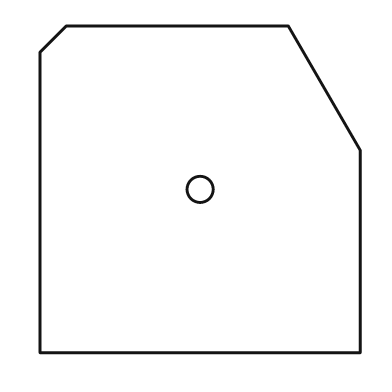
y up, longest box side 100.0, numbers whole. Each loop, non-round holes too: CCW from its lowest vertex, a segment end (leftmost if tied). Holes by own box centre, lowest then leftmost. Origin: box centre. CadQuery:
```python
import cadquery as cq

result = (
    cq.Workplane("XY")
    .moveTo(-49.0, -50.0)
    .lineTo(49.0, -50.0)
    .lineTo(49.0, 12.0)
    .lineTo(27.0, 50.0)
    .lineTo(-41.0, 50.0)
    .lineTo(-49.0, 42.0)
    .close()
    .moveTo(0.0, 0.0)
    .circle(4.0)
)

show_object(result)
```